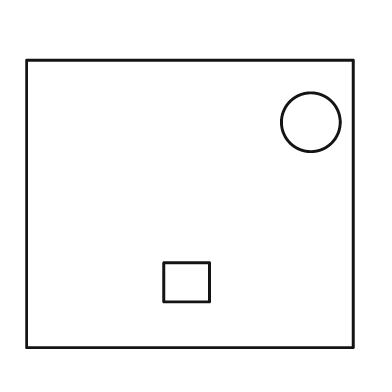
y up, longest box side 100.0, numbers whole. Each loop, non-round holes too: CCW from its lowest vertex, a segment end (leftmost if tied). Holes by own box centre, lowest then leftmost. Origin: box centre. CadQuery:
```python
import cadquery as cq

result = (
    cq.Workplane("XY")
    .moveTo(-50.0, -44.0)
    .lineTo(50.0, -44.0)
    .lineTo(50.0, 44.0)
    .lineTo(-50.0, 44.0)
    .close()
    .moveTo(-8.0, -30.0)
    .lineTo(6.0, -30.0)
    .lineTo(6.0, -18.0)
    .lineTo(-8.0, -18.0)
    .close()
    .moveTo(37.0, 25.0)
    .circle(9.0)
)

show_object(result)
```